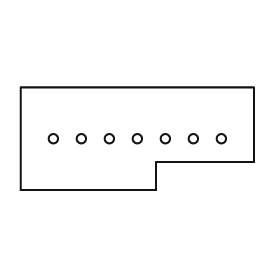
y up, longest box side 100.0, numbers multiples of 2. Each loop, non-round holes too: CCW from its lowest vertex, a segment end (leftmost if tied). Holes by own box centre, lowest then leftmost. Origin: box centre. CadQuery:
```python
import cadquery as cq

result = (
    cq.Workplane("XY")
    .moveTo(-50.0, -22.0)
    .lineTo(8.0, -22.0)
    .lineTo(8.0, -10.0)
    .lineTo(50.0, -10.0)
    .lineTo(50.0, 22.0)
    .lineTo(-50.0, 22.0)
    .close()
    .moveTo(-36.0, 0.0)
    .circle(2.0)
    .moveTo(-24.0, 0.0)
    .circle(2.0)
    .moveTo(-12.0, 0.0)
    .circle(2.0)
    .moveTo(0.0, 0.0)
    .circle(2.0)
    .moveTo(12.0, 0.0)
    .circle(2.0)
    .moveTo(24.0, 0.0)
    .circle(2.0)
    .moveTo(36.0, 0.0)
    .circle(2.0)
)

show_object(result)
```